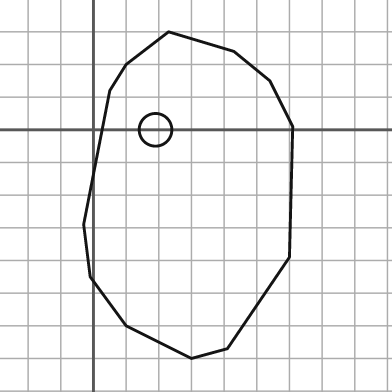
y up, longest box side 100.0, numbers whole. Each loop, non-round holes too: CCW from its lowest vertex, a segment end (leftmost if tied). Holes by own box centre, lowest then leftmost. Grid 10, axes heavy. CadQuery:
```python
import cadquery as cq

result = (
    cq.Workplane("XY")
    .moveTo(30.0, -70.0)
    .lineTo(41.0, -67.0)
    .lineTo(60.0, -39.0)
    .lineTo(61.0, 1.0)
    .lineTo(54.0, 15.0)
    .lineTo(43.0, 24.0)
    .lineTo(23.0, 30.0)
    .lineTo(10.0, 20.0)
    .lineTo(5.0, 12.0)
    .lineTo(-3.0, -29.0)
    .lineTo(-1.0, -45.0)
    .lineTo(10.0, -60.0)
    .close()
    .moveTo(19.0, 0.0)
    .circle(5.0)
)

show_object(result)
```